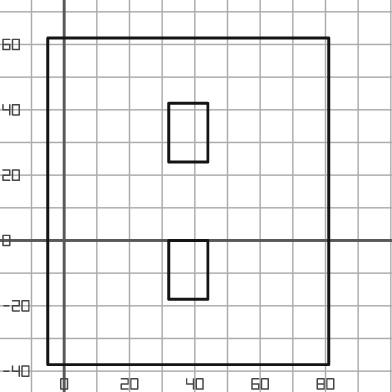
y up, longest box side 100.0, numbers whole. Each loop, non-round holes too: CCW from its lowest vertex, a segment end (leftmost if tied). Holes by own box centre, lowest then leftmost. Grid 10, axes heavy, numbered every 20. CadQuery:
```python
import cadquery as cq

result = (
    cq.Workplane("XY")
    .moveTo(-5.0, -38.0)
    .lineTo(81.0, -38.0)
    .lineTo(81.0, 62.0)
    .lineTo(-5.0, 62.0)
    .close()
    .moveTo(32.0, -18.0)
    .lineTo(44.0, -18.0)
    .lineTo(44.0, 0.0)
    .lineTo(32.0, 0.0)
    .close()
    .moveTo(32.0, 24.0)
    .lineTo(44.0, 24.0)
    .lineTo(44.0, 42.0)
    .lineTo(32.0, 42.0)
    .close()
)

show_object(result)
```